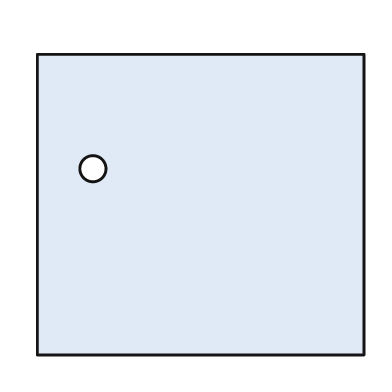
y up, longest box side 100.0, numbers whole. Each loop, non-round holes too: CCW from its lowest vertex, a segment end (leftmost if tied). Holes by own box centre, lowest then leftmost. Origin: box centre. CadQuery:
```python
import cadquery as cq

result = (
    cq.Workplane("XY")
    .moveTo(-50.0, -46.0)
    .lineTo(50.0, -46.0)
    .lineTo(50.0, 46.0)
    .lineTo(-50.0, 46.0)
    .close()
    .moveTo(-33.0, 11.0)
    .circle(4.0)
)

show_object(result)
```